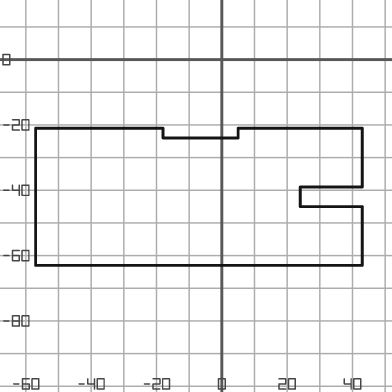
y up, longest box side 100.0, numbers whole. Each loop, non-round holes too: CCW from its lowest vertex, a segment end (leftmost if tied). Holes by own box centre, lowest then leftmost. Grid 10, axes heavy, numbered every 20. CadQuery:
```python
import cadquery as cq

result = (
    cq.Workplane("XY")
    .moveTo(-57.0, -63.0)
    .lineTo(43.0, -63.0)
    .lineTo(43.0, -45.0)
    .lineTo(24.0, -45.0)
    .lineTo(24.0, -39.0)
    .lineTo(43.0, -39.0)
    .lineTo(43.0, -21.0)
    .lineTo(5.0, -21.0)
    .lineTo(5.0, -24.0)
    .lineTo(-18.0, -24.0)
    .lineTo(-18.0, -21.0)
    .lineTo(-57.0, -21.0)
    .close()
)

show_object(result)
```